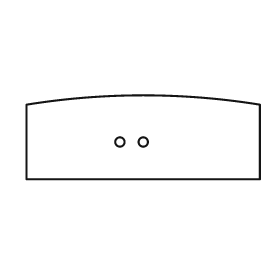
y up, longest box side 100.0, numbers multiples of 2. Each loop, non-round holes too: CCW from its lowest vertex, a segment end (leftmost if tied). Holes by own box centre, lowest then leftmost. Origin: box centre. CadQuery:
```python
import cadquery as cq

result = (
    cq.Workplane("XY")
    .moveTo(-50.0, -18.0)
    .lineTo(50.0, -18.0)
    .lineTo(50.0, 14.0)
    .threePointArc((0.0, 18.0), (-50.0, 14.0))
    .close()
    .moveTo(-10.0, -2.0)
    .circle(2.0)
    .moveTo(0.0, -2.0)
    .circle(2.0)
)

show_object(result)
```